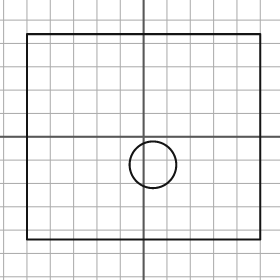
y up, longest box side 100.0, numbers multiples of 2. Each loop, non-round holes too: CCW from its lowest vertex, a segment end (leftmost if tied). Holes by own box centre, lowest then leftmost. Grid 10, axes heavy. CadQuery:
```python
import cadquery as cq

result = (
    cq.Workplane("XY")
    .moveTo(-50.0, -44.0)
    .lineTo(50.0, -44.0)
    .lineTo(50.0, 44.0)
    .lineTo(-50.0, 44.0)
    .close()
    .moveTo(4.0, -12.0)
    .circle(10.0)
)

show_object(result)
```